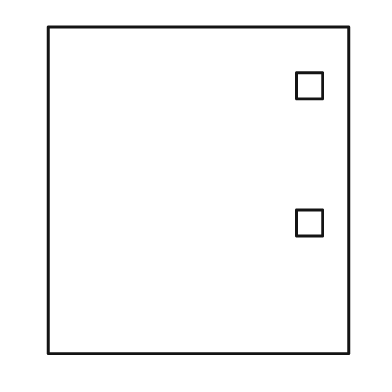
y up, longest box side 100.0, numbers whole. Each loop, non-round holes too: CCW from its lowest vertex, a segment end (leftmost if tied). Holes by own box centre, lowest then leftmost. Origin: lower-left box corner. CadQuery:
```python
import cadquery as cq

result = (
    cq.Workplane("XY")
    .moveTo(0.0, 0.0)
    .lineTo(92.0, 0.0)
    .lineTo(92.0, 100.0)
    .lineTo(0.0, 100.0)
    .close()
    .moveTo(76.0, 36.0)
    .lineTo(84.0, 36.0)
    .lineTo(84.0, 44.0)
    .lineTo(76.0, 44.0)
    .close()
    .moveTo(76.0, 78.0)
    .lineTo(84.0, 78.0)
    .lineTo(84.0, 86.0)
    .lineTo(76.0, 86.0)
    .close()
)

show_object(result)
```